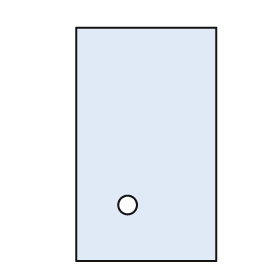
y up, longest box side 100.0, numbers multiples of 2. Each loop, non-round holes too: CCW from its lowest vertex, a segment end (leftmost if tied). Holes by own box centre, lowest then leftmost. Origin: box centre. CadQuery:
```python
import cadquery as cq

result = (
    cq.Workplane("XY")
    .moveTo(-30.0, -50.0)
    .lineTo(30.0, -50.0)
    .lineTo(30.0, 50.0)
    .lineTo(-30.0, 50.0)
    .close()
    .moveTo(-8.0, -26.0)
    .circle(4.0)
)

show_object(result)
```